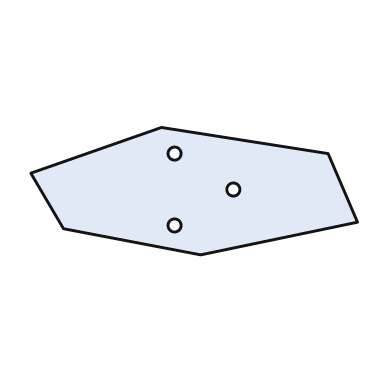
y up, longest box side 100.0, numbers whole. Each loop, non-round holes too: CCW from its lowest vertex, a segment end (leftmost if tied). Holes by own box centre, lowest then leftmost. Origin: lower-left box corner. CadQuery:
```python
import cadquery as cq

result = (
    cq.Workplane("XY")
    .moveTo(52.0, 0.0)
    .lineTo(100.0, 10.0)
    .lineTo(91.0, 31.0)
    .lineTo(40.0, 39.0)
    .lineTo(0.0, 25.0)
    .lineTo(10.0, 8.0)
    .close()
    .moveTo(44.0, 9.0)
    .circle(2.0)
    .moveTo(62.0, 20.0)
    .circle(2.0)
    .moveTo(44.0, 31.0)
    .circle(2.0)
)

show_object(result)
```